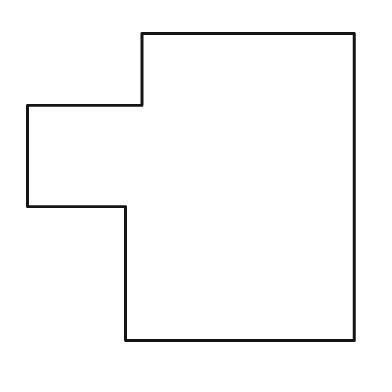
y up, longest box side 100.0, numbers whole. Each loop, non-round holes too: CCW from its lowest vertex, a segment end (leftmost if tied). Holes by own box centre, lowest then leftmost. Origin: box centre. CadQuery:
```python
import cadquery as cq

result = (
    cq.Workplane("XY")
    .moveTo(-20.0, -47.0)
    .lineTo(50.0, -47.0)
    .lineTo(50.0, 47.0)
    .lineTo(-15.0, 47.0)
    .lineTo(-15.0, 25.0)
    .lineTo(-50.0, 25.0)
    .lineTo(-50.0, -6.0)
    .lineTo(-20.0, -6.0)
    .close()
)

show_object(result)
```